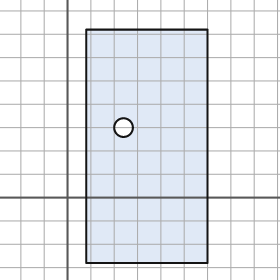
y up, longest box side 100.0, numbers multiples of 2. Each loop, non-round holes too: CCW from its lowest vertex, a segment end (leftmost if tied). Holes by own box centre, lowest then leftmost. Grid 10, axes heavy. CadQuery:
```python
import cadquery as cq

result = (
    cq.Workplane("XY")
    .moveTo(8.0, -28.0)
    .lineTo(60.0, -28.0)
    .lineTo(60.0, 72.0)
    .lineTo(8.0, 72.0)
    .close()
    .moveTo(24.0, 30.0)
    .circle(4.0)
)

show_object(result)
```